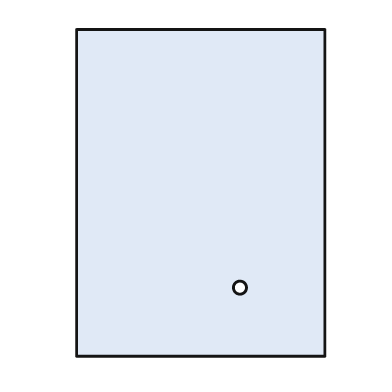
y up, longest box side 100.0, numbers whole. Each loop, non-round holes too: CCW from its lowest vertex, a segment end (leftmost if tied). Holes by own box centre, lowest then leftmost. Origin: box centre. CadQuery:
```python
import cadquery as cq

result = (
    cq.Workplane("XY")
    .moveTo(-38.0, -50.0)
    .lineTo(38.0, -50.0)
    .lineTo(38.0, 50.0)
    .lineTo(-38.0, 50.0)
    .close()
    .moveTo(12.0, -29.0)
    .circle(2.0)
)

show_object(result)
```